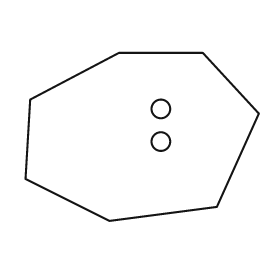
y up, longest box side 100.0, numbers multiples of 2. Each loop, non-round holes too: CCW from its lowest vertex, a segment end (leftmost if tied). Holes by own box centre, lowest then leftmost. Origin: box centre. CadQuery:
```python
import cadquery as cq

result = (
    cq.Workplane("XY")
    .moveTo(-14.0, -36.0)
    .lineTo(32.0, -30.0)
    .lineTo(50.0, 10.0)
    .lineTo(26.0, 36.0)
    .lineTo(-10.0, 36.0)
    .lineTo(-48.0, 16.0)
    .lineTo(-50.0, -18.0)
    .close()
    .moveTo(8.0, -2.0)
    .circle(4.0)
    .moveTo(8.0, 12.0)
    .circle(4.0)
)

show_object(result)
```